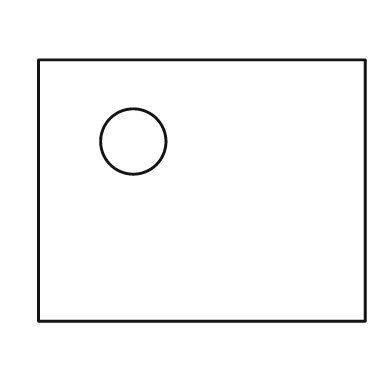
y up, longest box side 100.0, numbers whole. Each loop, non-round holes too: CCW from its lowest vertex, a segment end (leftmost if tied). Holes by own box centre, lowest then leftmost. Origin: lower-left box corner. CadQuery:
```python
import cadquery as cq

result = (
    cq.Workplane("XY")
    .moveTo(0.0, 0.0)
    .lineTo(100.0, 0.0)
    .lineTo(100.0, 80.0)
    .lineTo(0.0, 80.0)
    .close()
    .moveTo(29.0, 55.0)
    .circle(10.0)
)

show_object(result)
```